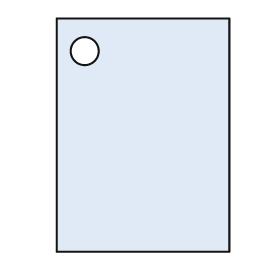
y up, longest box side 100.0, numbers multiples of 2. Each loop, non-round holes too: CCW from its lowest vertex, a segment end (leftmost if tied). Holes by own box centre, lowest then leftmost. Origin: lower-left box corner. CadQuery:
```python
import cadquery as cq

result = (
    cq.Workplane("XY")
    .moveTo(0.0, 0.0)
    .lineTo(74.0, 0.0)
    .lineTo(74.0, 100.0)
    .lineTo(0.0, 100.0)
    .close()
    .moveTo(12.0, 86.0)
    .circle(6.0)
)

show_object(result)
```